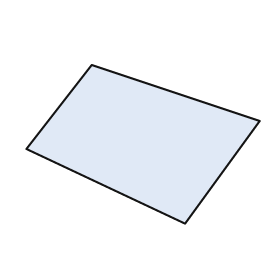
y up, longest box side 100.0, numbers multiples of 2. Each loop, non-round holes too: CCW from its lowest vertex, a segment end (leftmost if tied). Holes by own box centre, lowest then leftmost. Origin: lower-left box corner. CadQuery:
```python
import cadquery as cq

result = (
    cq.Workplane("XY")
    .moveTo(68.0, 0.0)
    .lineTo(100.0, 44.0)
    .lineTo(28.0, 68.0)
    .lineTo(0.0, 32.0)
    .close()
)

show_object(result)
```